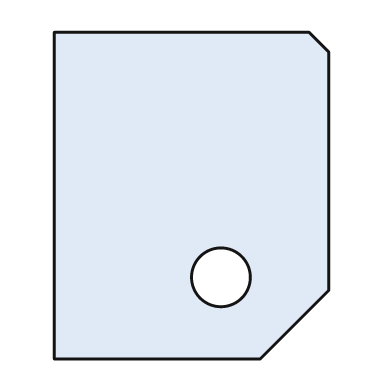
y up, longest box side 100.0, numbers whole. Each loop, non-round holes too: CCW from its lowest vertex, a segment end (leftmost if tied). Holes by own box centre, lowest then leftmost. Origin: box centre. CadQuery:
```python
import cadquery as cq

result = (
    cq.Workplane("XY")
    .moveTo(-42.0, -50.0)
    .lineTo(21.0, -50.0)
    .lineTo(42.0, -29.0)
    .lineTo(42.0, 44.0)
    .lineTo(36.0, 50.0)
    .lineTo(-42.0, 50.0)
    .close()
    .moveTo(9.0, -25.0)
    .circle(9.0)
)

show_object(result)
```